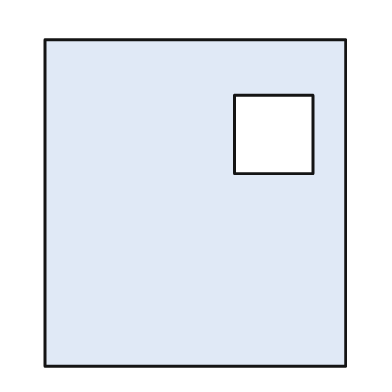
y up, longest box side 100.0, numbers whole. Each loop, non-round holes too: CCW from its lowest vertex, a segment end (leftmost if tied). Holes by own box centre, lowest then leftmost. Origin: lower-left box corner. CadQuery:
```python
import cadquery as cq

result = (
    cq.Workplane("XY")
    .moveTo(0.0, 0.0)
    .lineTo(92.0, 0.0)
    .lineTo(92.0, 100.0)
    .lineTo(0.0, 100.0)
    .close()
    .moveTo(58.0, 59.0)
    .lineTo(82.0, 59.0)
    .lineTo(82.0, 83.0)
    .lineTo(58.0, 83.0)
    .close()
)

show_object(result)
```